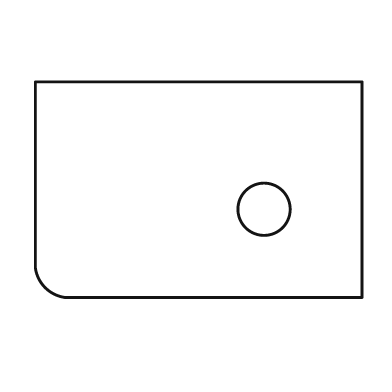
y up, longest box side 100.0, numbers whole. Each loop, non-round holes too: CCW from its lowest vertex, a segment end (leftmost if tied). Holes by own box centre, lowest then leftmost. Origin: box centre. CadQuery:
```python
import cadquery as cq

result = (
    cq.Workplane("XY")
    .moveTo(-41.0, -33.0)
    .lineTo(50.0, -33.0)
    .lineTo(50.0, 33.0)
    .lineTo(-50.0, 33.0)
    .lineTo(-50.0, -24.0)
    .threePointArc((-47.0, -30.0), (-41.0, -33.0))
    .close()
    .moveTo(20.0, -6.0)
    .circle(8.0)
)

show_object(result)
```